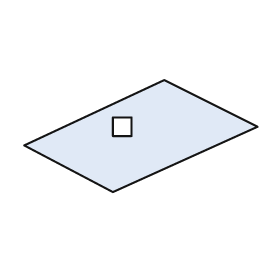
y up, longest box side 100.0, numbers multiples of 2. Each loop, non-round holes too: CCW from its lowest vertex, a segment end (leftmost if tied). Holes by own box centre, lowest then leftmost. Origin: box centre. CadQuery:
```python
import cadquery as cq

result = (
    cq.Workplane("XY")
    .moveTo(-12.0, -24.0)
    .lineTo(50.0, 4.0)
    .lineTo(10.0, 24.0)
    .lineTo(-50.0, -4.0)
    .close()
    .moveTo(-12.0, 0.0)
    .lineTo(-4.0, 0.0)
    .lineTo(-4.0, 8.0)
    .lineTo(-12.0, 8.0)
    .close()
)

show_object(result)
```